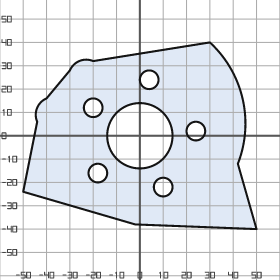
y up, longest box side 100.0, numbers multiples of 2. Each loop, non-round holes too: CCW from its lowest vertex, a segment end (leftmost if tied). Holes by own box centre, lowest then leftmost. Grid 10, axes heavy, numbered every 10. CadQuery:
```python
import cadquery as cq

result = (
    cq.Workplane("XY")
    .moveTo(50.0, -40.0)
    .lineTo(42.0, -12.0)
    .threePointArc((44.0, 16.0), (30.0, 40.0))
    .lineTo(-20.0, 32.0)
    .threePointArc((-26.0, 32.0), (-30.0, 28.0))
    .lineTo(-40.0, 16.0)
    .threePointArc((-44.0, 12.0), (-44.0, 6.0))
    .lineTo(-50.0, -24.0)
    .lineTo(-2.0, -38.0)
    .close()
    .moveTo(10.0, -22.0)
    .circle(4.0)
    .moveTo(-18.0, -16.0)
    .circle(4.0)
    .moveTo(0.0, 0.0)
    .circle(14.0)
    .moveTo(24.0, 2.0)
    .circle(4.0)
    .moveTo(-20.0, 12.0)
    .circle(4.0)
    .moveTo(4.0, 24.0)
    .circle(4.0)
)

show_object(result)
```